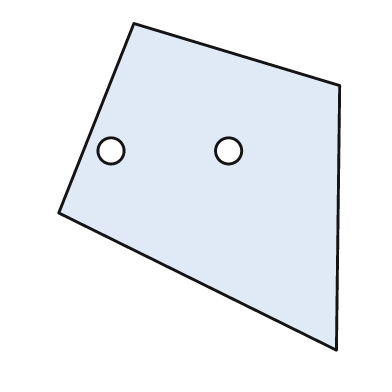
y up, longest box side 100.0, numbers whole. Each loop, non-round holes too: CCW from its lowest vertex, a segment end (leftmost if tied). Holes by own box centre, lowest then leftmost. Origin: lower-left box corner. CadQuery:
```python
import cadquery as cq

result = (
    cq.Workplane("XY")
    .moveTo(85.0, 0.0)
    .lineTo(86.0, 81.0)
    .lineTo(23.0, 100.0)
    .lineTo(0.0, 42.0)
    .close()
    .moveTo(16.0, 61.0)
    .circle(4.0)
    .moveTo(52.0, 61.0)
    .circle(4.0)
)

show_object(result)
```